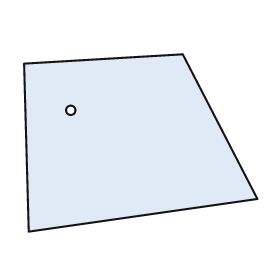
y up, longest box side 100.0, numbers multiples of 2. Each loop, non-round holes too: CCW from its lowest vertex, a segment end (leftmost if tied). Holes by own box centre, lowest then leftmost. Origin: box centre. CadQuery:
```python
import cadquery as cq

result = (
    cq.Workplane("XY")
    .moveTo(-48.0, -38.0)
    .lineTo(50.0, -24.0)
    .lineTo(18.0, 38.0)
    .lineTo(-50.0, 34.0)
    .close()
    .moveTo(-30.0, 14.0)
    .circle(2.0)
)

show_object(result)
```